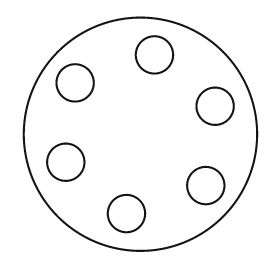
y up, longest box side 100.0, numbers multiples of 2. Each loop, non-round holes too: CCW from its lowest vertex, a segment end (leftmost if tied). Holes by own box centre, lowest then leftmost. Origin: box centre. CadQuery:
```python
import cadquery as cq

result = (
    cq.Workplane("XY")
    .moveTo(0.0, 0.0)
    .circle(50.0)
    .moveTo(-6.0, -34.0)
    .circle(8.0)
    .moveTo(28.0, -22.0)
    .circle(8.0)
    .moveTo(-32.0, -12.0)
    .circle(8.0)
    .moveTo(32.0, 12.0)
    .circle(8.0)
    .moveTo(-28.0, 22.0)
    .circle(8.0)
    .moveTo(6.0, 34.0)
    .circle(8.0)
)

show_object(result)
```